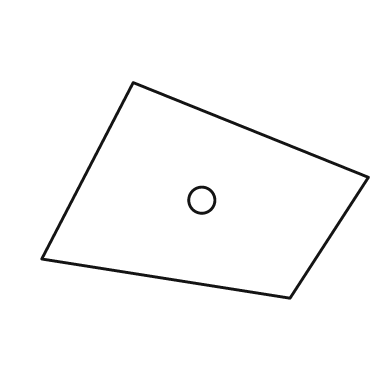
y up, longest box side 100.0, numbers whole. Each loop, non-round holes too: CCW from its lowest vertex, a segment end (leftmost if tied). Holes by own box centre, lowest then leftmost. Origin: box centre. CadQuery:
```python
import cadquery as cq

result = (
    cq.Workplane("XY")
    .moveTo(26.0, -33.0)
    .lineTo(50.0, 4.0)
    .lineTo(-22.0, 33.0)
    .lineTo(-50.0, -21.0)
    .close()
    .moveTo(-1.0, -3.0)
    .circle(4.0)
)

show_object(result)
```